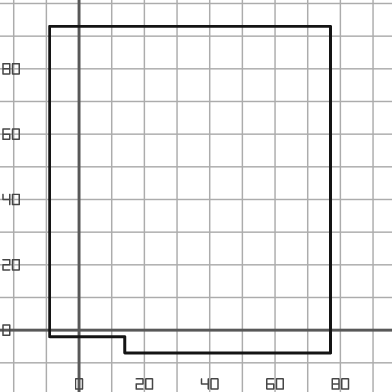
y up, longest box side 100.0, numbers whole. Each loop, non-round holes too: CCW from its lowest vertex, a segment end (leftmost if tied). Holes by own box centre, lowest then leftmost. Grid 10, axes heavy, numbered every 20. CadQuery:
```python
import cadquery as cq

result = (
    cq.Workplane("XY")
    .moveTo(14.0, -7.0)
    .lineTo(77.0, -7.0)
    .lineTo(77.0, 93.0)
    .lineTo(-9.0, 93.0)
    .lineTo(-9.0, -2.0)
    .lineTo(14.0, -2.0)
    .close()
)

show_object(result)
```